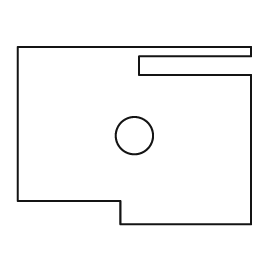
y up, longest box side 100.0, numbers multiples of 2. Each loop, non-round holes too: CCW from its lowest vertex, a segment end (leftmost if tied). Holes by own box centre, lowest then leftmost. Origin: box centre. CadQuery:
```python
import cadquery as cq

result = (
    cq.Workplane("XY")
    .moveTo(-6.0, -38.0)
    .lineTo(50.0, -38.0)
    .lineTo(50.0, 26.0)
    .lineTo(2.0, 26.0)
    .lineTo(2.0, 34.0)
    .lineTo(50.0, 34.0)
    .lineTo(50.0, 38.0)
    .lineTo(-50.0, 38.0)
    .lineTo(-50.0, -28.0)
    .lineTo(-6.0, -28.0)
    .close()
    .moveTo(0.0, 0.0)
    .circle(8.0)
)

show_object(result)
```